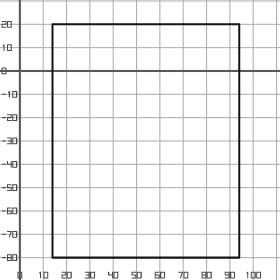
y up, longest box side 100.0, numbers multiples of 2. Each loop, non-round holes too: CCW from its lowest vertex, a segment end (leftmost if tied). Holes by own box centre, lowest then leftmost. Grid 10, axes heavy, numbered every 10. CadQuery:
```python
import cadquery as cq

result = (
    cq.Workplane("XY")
    .moveTo(14.0, -80.0)
    .lineTo(94.0, -80.0)
    .lineTo(94.0, 20.0)
    .lineTo(14.0, 20.0)
    .close()
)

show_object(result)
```